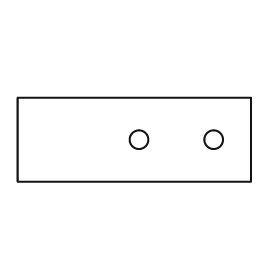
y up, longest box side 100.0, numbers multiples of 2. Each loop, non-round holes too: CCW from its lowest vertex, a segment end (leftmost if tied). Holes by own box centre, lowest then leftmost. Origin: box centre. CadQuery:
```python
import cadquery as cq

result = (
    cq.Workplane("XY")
    .moveTo(-50.0, -18.0)
    .lineTo(50.0, -18.0)
    .lineTo(50.0, 18.0)
    .lineTo(-50.0, 18.0)
    .close()
    .moveTo(2.0, 0.0)
    .circle(4.0)
    .moveTo(34.0, 0.0)
    .circle(4.0)
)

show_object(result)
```